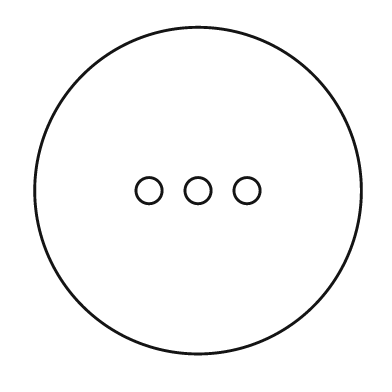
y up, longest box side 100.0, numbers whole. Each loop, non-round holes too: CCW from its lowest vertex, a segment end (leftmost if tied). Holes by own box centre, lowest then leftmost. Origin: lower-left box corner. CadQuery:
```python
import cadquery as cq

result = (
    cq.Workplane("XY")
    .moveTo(50.0, 50.0)
    .circle(50.0)
    .moveTo(35.0, 50.0)
    .circle(4.0)
    .moveTo(50.0, 50.0)
    .circle(4.0)
    .moveTo(65.0, 50.0)
    .circle(4.0)
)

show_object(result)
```